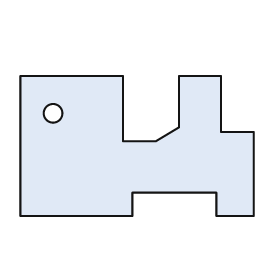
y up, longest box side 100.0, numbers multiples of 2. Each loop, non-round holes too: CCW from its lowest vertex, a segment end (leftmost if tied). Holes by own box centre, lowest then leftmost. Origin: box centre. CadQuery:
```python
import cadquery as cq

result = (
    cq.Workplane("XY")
    .moveTo(-50.0, -30.0)
    .lineTo(-2.0, -30.0)
    .lineTo(-2.0, -20.0)
    .lineTo(34.0, -20.0)
    .lineTo(34.0, -30.0)
    .lineTo(50.0, -30.0)
    .lineTo(50.0, 6.0)
    .lineTo(36.0, 6.0)
    .lineTo(36.0, 30.0)
    .lineTo(18.0, 30.0)
    .lineTo(18.0, 8.0)
    .lineTo(8.0, 2.0)
    .lineTo(-6.0, 2.0)
    .lineTo(-6.0, 30.0)
    .lineTo(-50.0, 30.0)
    .close()
    .moveTo(-36.0, 14.0)
    .circle(4.0)
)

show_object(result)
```